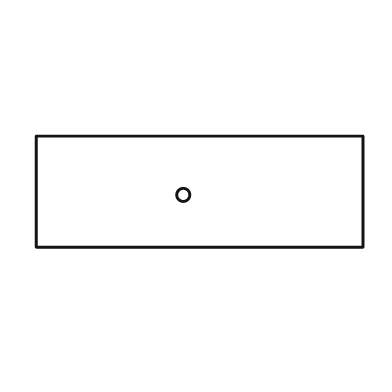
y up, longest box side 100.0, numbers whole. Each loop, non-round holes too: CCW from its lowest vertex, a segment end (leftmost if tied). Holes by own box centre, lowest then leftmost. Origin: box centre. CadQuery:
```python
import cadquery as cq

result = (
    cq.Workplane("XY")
    .moveTo(-50.0, -17.0)
    .lineTo(50.0, -17.0)
    .lineTo(50.0, 17.0)
    .lineTo(-50.0, 17.0)
    .close()
    .moveTo(-5.0, -1.0)
    .circle(2.0)
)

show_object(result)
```